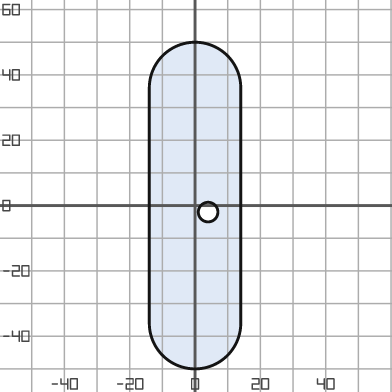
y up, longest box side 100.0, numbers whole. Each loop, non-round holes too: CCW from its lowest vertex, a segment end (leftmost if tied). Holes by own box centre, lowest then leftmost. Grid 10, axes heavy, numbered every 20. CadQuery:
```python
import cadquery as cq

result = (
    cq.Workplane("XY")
    .moveTo(-14.0, -36.0)
    .threePointArc((0.0, -50.0), (14.0, -36.0))
    .lineTo(14.0, 36.0)
    .threePointArc((0.0, 50.0), (-14.0, 36.0))
    .close()
    .moveTo(4.0, -2.0)
    .circle(3.0)
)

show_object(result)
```